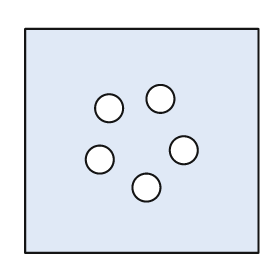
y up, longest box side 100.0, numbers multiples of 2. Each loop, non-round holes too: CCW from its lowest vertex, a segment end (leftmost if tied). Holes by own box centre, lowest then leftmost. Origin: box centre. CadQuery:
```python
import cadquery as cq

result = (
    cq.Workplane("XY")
    .moveTo(-50.0, -48.0)
    .lineTo(50.0, -48.0)
    .lineTo(50.0, 48.0)
    .lineTo(-50.0, 48.0)
    .close()
    .moveTo(2.0, -20.0)
    .circle(6.0)
    .moveTo(-18.0, -8.0)
    .circle(6.0)
    .moveTo(18.0, -4.0)
    .circle(6.0)
    .moveTo(-14.0, 14.0)
    .circle(6.0)
    .moveTo(8.0, 18.0)
    .circle(6.0)
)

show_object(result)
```